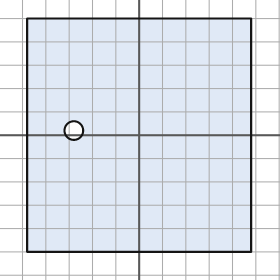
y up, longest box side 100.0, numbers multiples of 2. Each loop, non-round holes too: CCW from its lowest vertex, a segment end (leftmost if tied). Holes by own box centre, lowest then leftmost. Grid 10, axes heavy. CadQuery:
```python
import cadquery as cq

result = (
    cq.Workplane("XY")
    .moveTo(-48.0, -50.0)
    .lineTo(48.0, -50.0)
    .lineTo(48.0, 50.0)
    .lineTo(-48.0, 50.0)
    .close()
    .moveTo(-28.0, 2.0)
    .circle(4.0)
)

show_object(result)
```